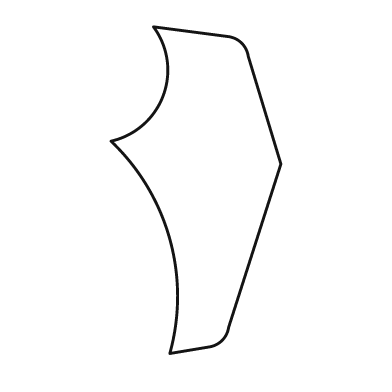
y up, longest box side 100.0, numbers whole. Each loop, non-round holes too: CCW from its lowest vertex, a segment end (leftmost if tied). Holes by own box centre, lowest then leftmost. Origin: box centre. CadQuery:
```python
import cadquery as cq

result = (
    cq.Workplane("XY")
    .moveTo(-8.0, -50.0)
    .lineTo(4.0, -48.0)
    .threePointArc((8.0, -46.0), (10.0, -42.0))
    .lineTo(26.0, 8.0)
    .lineTo(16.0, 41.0)
    .threePointArc((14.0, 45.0), (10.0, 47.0))
    .lineTo(-13.0, 50.0)
    .threePointArc((-10.0, 29.0), (-26.0, 15.0))
    .threePointArc((-8.0, -15.0), (-8.0, -50.0))
    .close()
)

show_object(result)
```